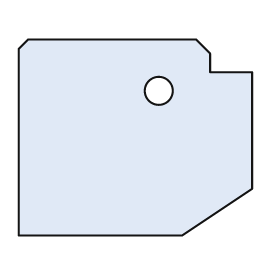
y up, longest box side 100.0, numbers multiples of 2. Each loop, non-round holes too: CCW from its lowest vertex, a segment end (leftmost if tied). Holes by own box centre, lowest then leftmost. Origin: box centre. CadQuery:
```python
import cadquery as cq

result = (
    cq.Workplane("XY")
    .moveTo(-50.0, -42.0)
    .lineTo(20.0, -42.0)
    .lineTo(50.0, -22.0)
    .lineTo(50.0, 28.0)
    .lineTo(32.0, 28.0)
    .lineTo(32.0, 36.0)
    .lineTo(26.0, 42.0)
    .lineTo(-46.0, 42.0)
    .lineTo(-50.0, 38.0)
    .close()
    .moveTo(10.0, 20.0)
    .circle(6.0)
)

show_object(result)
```